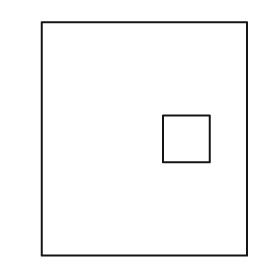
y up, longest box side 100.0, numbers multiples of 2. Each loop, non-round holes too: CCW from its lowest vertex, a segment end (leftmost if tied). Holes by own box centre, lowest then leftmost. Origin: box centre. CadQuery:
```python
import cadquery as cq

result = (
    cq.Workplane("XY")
    .moveTo(-44.0, -50.0)
    .lineTo(44.0, -50.0)
    .lineTo(44.0, 50.0)
    .lineTo(-44.0, 50.0)
    .close()
    .moveTo(8.0, -10.0)
    .lineTo(28.0, -10.0)
    .lineTo(28.0, 10.0)
    .lineTo(8.0, 10.0)
    .close()
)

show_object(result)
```